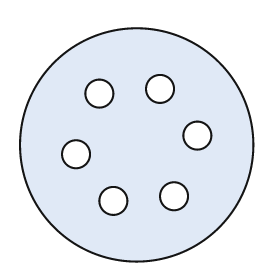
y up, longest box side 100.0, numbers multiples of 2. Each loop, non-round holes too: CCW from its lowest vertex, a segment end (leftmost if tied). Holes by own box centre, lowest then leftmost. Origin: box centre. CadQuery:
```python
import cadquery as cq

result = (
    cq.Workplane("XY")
    .moveTo(0.0, 0.0)
    .circle(50.0)
    .moveTo(-10.0, -24.0)
    .circle(6.0)
    .moveTo(16.0, -22.0)
    .circle(6.0)
    .moveTo(-26.0, -4.0)
    .circle(6.0)
    .moveTo(26.0, 4.0)
    .circle(6.0)
    .moveTo(-16.0, 22.0)
    .circle(6.0)
    .moveTo(10.0, 24.0)
    .circle(6.0)
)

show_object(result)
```